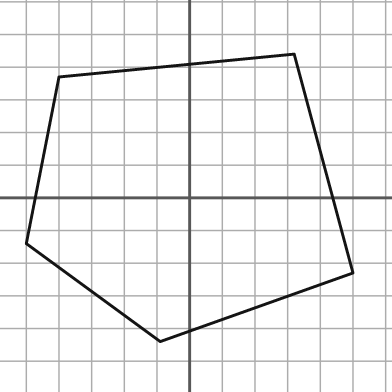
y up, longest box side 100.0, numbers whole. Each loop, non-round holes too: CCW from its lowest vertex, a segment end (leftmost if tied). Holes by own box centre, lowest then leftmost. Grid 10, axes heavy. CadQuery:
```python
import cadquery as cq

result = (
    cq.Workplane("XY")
    .moveTo(-9.0, -44.0)
    .lineTo(50.0, -23.0)
    .lineTo(32.0, 44.0)
    .lineTo(-40.0, 37.0)
    .lineTo(-50.0, -14.0)
    .close()
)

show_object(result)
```